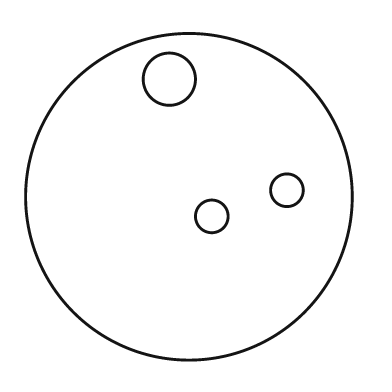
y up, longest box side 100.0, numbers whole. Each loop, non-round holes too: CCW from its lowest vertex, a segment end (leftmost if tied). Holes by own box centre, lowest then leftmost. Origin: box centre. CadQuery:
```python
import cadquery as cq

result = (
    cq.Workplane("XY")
    .moveTo(0.0, 0.0)
    .circle(50.0)
    .moveTo(7.0, -6.0)
    .circle(5.0)
    .moveTo(30.0, 2.0)
    .circle(5.0)
    .moveTo(-6.0, 36.0)
    .circle(8.0)
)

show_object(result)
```